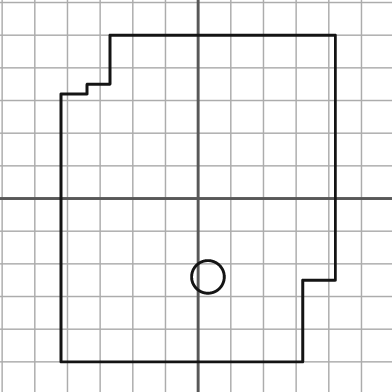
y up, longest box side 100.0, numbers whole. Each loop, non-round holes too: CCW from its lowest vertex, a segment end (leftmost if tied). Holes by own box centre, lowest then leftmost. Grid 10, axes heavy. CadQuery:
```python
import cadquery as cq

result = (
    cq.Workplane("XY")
    .moveTo(-42.0, -50.0)
    .lineTo(32.0, -50.0)
    .lineTo(32.0, -25.0)
    .lineTo(42.0, -25.0)
    .lineTo(42.0, 50.0)
    .lineTo(-27.0, 50.0)
    .lineTo(-27.0, 35.0)
    .lineTo(-34.0, 35.0)
    .lineTo(-34.0, 32.0)
    .lineTo(-42.0, 32.0)
    .close()
    .moveTo(3.0, -24.0)
    .circle(5.0)
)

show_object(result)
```